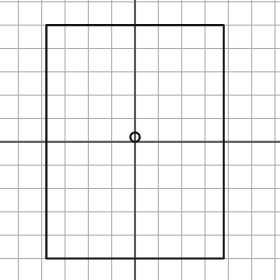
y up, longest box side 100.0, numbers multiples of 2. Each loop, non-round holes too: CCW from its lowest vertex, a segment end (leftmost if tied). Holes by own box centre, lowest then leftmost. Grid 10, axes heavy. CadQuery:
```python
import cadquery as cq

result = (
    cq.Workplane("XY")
    .moveTo(-38.0, -50.0)
    .lineTo(38.0, -50.0)
    .lineTo(38.0, 50.0)
    .lineTo(-38.0, 50.0)
    .close()
    .moveTo(0.0, 2.0)
    .circle(2.0)
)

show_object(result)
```